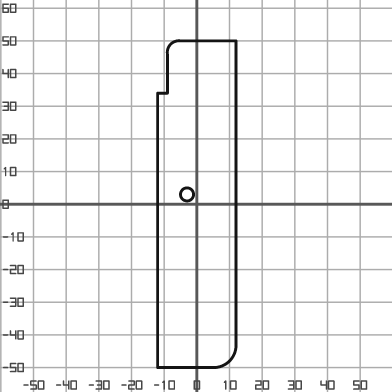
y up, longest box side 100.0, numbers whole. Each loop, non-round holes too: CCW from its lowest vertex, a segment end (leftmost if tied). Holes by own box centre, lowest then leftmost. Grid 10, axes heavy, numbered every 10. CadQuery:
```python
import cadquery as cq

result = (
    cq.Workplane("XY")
    .moveTo(-12.0, -50.0)
    .lineTo(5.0, -50.0)
    .threePointArc((10.0, -48.0), (12.0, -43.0))
    .lineTo(12.0, 50.0)
    .lineTo(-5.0, 50.0)
    .threePointArc((-8.0, 49.0), (-9.0, 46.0))
    .lineTo(-9.0, 34.0)
    .lineTo(-12.0, 34.0)
    .close()
    .moveTo(-3.0, 3.0)
    .circle(2.0)
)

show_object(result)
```